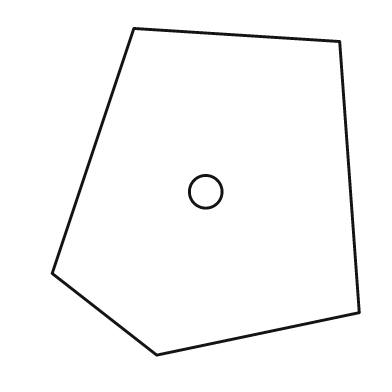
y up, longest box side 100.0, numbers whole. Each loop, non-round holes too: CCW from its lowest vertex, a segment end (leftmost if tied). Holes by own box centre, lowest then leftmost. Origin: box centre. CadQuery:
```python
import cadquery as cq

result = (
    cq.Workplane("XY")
    .moveTo(-15.0, -50.0)
    .lineTo(47.0, -37.0)
    .lineTo(41.0, 46.0)
    .lineTo(-22.0, 50.0)
    .lineTo(-47.0, -25.0)
    .close()
    .moveTo(0.0, 0.0)
    .circle(5.0)
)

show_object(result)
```